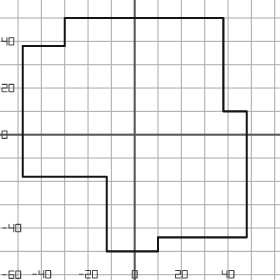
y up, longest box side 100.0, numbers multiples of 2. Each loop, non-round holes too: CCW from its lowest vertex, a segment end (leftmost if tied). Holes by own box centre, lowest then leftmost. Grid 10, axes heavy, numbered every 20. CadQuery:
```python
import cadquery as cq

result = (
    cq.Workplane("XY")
    .moveTo(-12.0, -50.0)
    .lineTo(10.0, -50.0)
    .lineTo(10.0, -44.0)
    .lineTo(48.0, -44.0)
    .lineTo(48.0, 10.0)
    .lineTo(38.0, 10.0)
    .lineTo(38.0, 50.0)
    .lineTo(-30.0, 50.0)
    .lineTo(-30.0, 38.0)
    .lineTo(-48.0, 38.0)
    .lineTo(-48.0, -18.0)
    .lineTo(-12.0, -18.0)
    .close()
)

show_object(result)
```